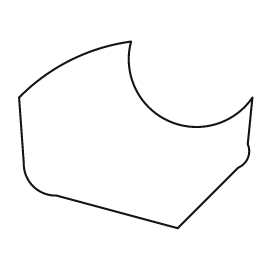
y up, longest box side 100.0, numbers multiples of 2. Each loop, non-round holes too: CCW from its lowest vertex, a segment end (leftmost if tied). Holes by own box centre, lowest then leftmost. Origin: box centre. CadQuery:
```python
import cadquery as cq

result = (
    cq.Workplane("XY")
    .moveTo(18.0, -40.0)
    .lineTo(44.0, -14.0)
    .threePointArc((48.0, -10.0), (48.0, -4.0))
    .lineTo(50.0, 16.0)
    .threePointArc((14.0, 6.0), (-2.0, 40.0))
    .threePointArc((-28.0, 32.0), (-50.0, 16.0))
    .lineTo(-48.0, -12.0)
    .threePointArc((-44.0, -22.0), (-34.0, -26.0))
    .close()
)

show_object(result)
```